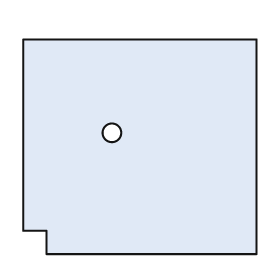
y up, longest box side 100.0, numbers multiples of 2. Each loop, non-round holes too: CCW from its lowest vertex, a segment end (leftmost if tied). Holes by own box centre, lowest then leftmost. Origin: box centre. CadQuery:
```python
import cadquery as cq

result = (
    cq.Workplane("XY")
    .moveTo(-40.0, -46.0)
    .lineTo(50.0, -46.0)
    .lineTo(50.0, 46.0)
    .lineTo(-50.0, 46.0)
    .lineTo(-50.0, -36.0)
    .lineTo(-40.0, -36.0)
    .close()
    .moveTo(-12.0, 6.0)
    .circle(4.0)
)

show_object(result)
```